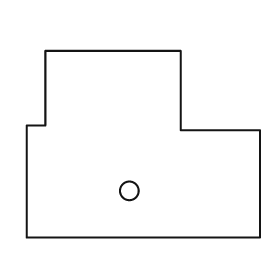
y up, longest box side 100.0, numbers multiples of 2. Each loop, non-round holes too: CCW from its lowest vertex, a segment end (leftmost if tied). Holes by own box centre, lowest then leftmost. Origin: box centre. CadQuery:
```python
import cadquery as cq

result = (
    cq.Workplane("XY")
    .moveTo(-50.0, -40.0)
    .lineTo(50.0, -40.0)
    .lineTo(50.0, 6.0)
    .lineTo(16.0, 6.0)
    .lineTo(16.0, 40.0)
    .lineTo(-42.0, 40.0)
    .lineTo(-42.0, 8.0)
    .lineTo(-50.0, 8.0)
    .close()
    .moveTo(-6.0, -20.0)
    .circle(4.0)
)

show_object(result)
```